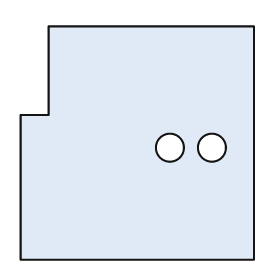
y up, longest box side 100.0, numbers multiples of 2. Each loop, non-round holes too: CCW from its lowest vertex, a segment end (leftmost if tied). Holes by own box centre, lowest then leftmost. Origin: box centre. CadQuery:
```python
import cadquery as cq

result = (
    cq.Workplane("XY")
    .moveTo(-50.0, -50.0)
    .lineTo(50.0, -50.0)
    .lineTo(50.0, 50.0)
    .lineTo(-38.0, 50.0)
    .lineTo(-38.0, 12.0)
    .lineTo(-50.0, 12.0)
    .close()
    .moveTo(14.0, -2.0)
    .circle(6.0)
    .moveTo(32.0, -2.0)
    .circle(6.0)
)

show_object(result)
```